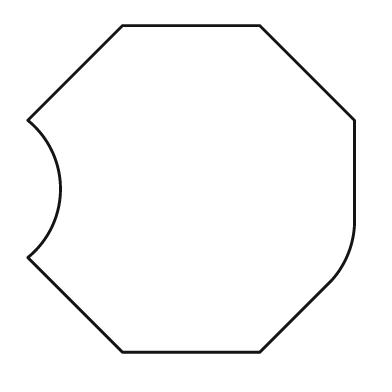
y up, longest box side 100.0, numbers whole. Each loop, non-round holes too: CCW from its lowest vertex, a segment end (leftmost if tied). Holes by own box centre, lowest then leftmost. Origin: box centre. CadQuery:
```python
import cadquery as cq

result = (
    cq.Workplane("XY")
    .moveTo(-21.0, -50.0)
    .lineTo(21.0, -50.0)
    .lineTo(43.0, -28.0)
    .threePointArc((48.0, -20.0), (50.0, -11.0))
    .lineTo(50.0, 21.0)
    .lineTo(21.0, 50.0)
    .lineTo(-21.0, 50.0)
    .lineTo(-50.0, 21.0)
    .threePointArc((-40.0, 0.0), (-50.0, -21.0))
    .close()
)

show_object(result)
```